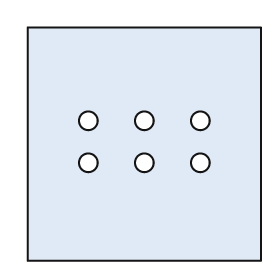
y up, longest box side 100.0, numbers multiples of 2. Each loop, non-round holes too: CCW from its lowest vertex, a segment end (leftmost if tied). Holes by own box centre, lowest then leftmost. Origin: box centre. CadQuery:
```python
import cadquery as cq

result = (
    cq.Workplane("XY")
    .moveTo(-50.0, -50.0)
    .lineTo(50.0, -50.0)
    .lineTo(50.0, 50.0)
    .lineTo(-50.0, 50.0)
    .close()
    .moveTo(-24.0, -8.0)
    .circle(4.0)
    .moveTo(0.0, -8.0)
    .circle(4.0)
    .moveTo(24.0, -8.0)
    .circle(4.0)
    .moveTo(-24.0, 10.0)
    .circle(4.0)
    .moveTo(0.0, 10.0)
    .circle(4.0)
    .moveTo(24.0, 10.0)
    .circle(4.0)
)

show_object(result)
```